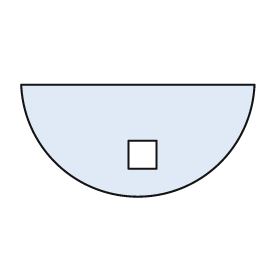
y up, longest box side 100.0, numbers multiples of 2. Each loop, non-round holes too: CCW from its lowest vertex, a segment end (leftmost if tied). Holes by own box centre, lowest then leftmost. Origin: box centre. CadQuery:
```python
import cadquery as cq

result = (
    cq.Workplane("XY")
    .moveTo(-50.0, 24.0)
    .threePointArc((0.0, -24.0), (50.0, 24.0))
    .close()
    .moveTo(-4.0, -12.0)
    .lineTo(8.0, -12.0)
    .lineTo(8.0, 0.0)
    .lineTo(-4.0, 0.0)
    .close()
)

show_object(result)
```